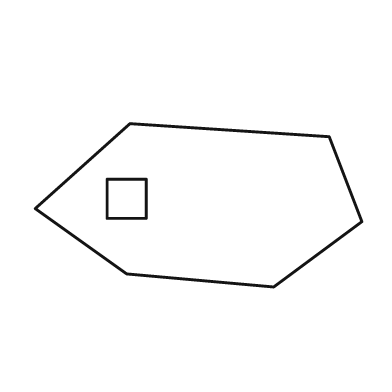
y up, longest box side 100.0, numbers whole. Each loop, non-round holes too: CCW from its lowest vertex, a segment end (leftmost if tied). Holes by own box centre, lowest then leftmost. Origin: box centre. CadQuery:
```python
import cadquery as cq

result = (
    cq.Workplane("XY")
    .moveTo(23.0, -25.0)
    .lineTo(50.0, -5.0)
    .lineTo(40.0, 21.0)
    .lineTo(-21.0, 25.0)
    .lineTo(-50.0, -1.0)
    .lineTo(-22.0, -21.0)
    .close()
    .moveTo(-28.0, -4.0)
    .lineTo(-16.0, -4.0)
    .lineTo(-16.0, 8.0)
    .lineTo(-28.0, 8.0)
    .close()
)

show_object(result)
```